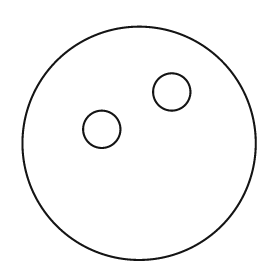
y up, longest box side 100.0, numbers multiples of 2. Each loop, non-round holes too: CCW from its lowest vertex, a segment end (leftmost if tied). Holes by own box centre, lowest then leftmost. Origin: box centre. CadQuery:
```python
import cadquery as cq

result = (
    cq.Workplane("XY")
    .moveTo(0.0, 0.0)
    .circle(50.0)
    .moveTo(-16.0, 6.0)
    .circle(8.0)
    .moveTo(14.0, 22.0)
    .circle(8.0)
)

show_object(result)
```